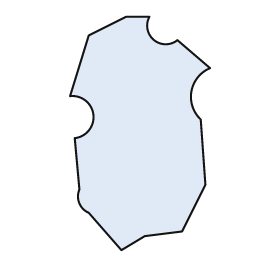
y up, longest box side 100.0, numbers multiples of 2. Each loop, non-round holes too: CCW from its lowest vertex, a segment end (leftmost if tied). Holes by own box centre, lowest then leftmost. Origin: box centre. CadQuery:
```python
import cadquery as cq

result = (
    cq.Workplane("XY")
    .moveTo(-8.0, -50.0)
    .lineTo(2.0, -44.0)
    .lineTo(18.0, -42.0)
    .lineTo(28.0, -22.0)
    .lineTo(26.0, 6.0)
    .threePointArc((22.0, 18.0), (30.0, 28.0))
    .lineTo(16.0, 40.0)
    .threePointArc((6.0, 40.0), (4.0, 50.0))
    .lineTo(-6.0, 50.0)
    .lineTo(-22.0, 42.0)
    .lineTo(-30.0, 16.0)
    .threePointArc((-20.0, 8.0), (-28.0, -2.0))
    .lineTo(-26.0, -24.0)
    .threePointArc((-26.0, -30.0), (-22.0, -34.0))
    .close()
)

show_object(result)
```